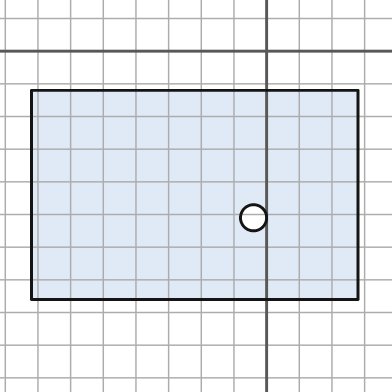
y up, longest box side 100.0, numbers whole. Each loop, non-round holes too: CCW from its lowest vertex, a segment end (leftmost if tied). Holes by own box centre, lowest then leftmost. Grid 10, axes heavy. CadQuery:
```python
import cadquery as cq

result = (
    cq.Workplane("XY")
    .moveTo(-72.0, -76.0)
    .lineTo(28.0, -76.0)
    .lineTo(28.0, -12.0)
    .lineTo(-72.0, -12.0)
    .close()
    .moveTo(-4.0, -51.0)
    .circle(4.0)
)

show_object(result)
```